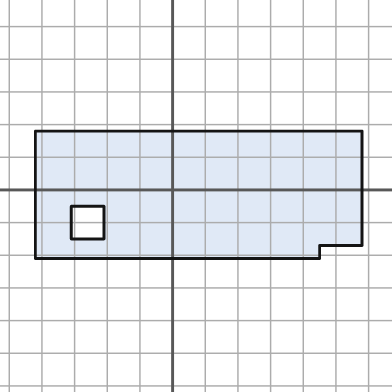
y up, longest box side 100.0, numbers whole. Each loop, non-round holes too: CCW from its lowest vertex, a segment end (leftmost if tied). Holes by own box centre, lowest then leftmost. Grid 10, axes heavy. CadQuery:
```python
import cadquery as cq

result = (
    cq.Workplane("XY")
    .moveTo(-42.0, -21.0)
    .lineTo(45.0, -21.0)
    .lineTo(45.0, -17.0)
    .lineTo(58.0, -17.0)
    .lineTo(58.0, 18.0)
    .lineTo(-42.0, 18.0)
    .close()
    .moveTo(-31.0, -15.0)
    .lineTo(-21.0, -15.0)
    .lineTo(-21.0, -5.0)
    .lineTo(-31.0, -5.0)
    .close()
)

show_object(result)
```